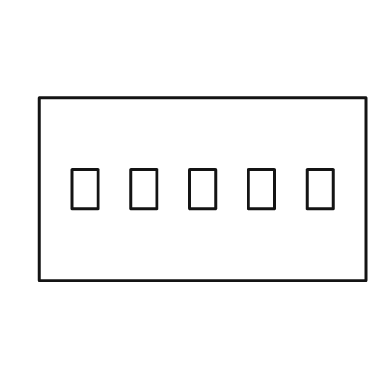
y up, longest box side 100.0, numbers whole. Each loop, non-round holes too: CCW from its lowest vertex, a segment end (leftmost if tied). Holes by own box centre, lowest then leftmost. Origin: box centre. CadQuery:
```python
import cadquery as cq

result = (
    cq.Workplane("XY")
    .moveTo(-50.0, -28.0)
    .lineTo(50.0, -28.0)
    .lineTo(50.0, 28.0)
    .lineTo(-50.0, 28.0)
    .close()
    .moveTo(-40.0, -6.0)
    .lineTo(-32.0, -6.0)
    .lineTo(-32.0, 6.0)
    .lineTo(-40.0, 6.0)
    .close()
    .moveTo(-22.0, -6.0)
    .lineTo(-14.0, -6.0)
    .lineTo(-14.0, 6.0)
    .lineTo(-22.0, 6.0)
    .close()
    .moveTo(-4.0, -6.0)
    .lineTo(4.0, -6.0)
    .lineTo(4.0, 6.0)
    .lineTo(-4.0, 6.0)
    .close()
    .moveTo(14.0, -6.0)
    .lineTo(22.0, -6.0)
    .lineTo(22.0, 6.0)
    .lineTo(14.0, 6.0)
    .close()
    .moveTo(32.0, -6.0)
    .lineTo(40.0, -6.0)
    .lineTo(40.0, 6.0)
    .lineTo(32.0, 6.0)
    .close()
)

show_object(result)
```